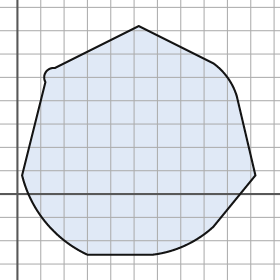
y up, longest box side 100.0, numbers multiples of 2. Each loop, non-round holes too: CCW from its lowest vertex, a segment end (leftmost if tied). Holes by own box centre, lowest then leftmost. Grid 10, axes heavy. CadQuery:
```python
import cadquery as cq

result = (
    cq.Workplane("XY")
    .moveTo(30.0, -26.0)
    .lineTo(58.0, -26.0)
    .threePointArc((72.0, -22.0), (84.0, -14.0))
    .lineTo(102.0, 8.0)
    .lineTo(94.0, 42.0)
    .threePointArc((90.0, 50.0), (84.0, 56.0))
    .lineTo(52.0, 72.0)
    .lineTo(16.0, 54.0)
    .threePointArc((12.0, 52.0), (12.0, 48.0))
    .lineTo(2.0, 8.0)
    .threePointArc((12.0, -12.0), (30.0, -26.0))
    .close()
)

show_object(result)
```